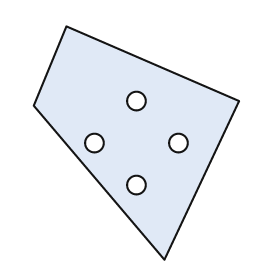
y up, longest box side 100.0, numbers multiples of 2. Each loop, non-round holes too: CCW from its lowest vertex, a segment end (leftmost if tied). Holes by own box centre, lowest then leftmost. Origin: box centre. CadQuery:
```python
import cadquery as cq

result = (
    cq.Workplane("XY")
    .moveTo(12.0, -50.0)
    .lineTo(44.0, 18.0)
    .lineTo(-30.0, 50.0)
    .lineTo(-44.0, 16.0)
    .close()
    .moveTo(0.0, -18.0)
    .circle(4.0)
    .moveTo(-18.0, 0.0)
    .circle(4.0)
    .moveTo(18.0, 0.0)
    .circle(4.0)
    .moveTo(0.0, 18.0)
    .circle(4.0)
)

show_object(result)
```